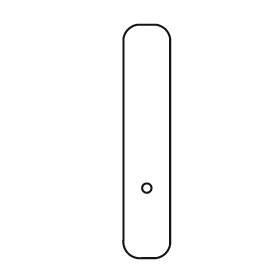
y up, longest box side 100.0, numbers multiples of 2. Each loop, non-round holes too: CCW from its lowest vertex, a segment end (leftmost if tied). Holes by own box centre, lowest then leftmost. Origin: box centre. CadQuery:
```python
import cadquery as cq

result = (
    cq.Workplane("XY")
    .moveTo(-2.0, -50.0)
    .lineTo(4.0, -50.0)
    .threePointArc((8.0, -48.0), (10.0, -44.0))
    .lineTo(10.0, 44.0)
    .threePointArc((8.0, 48.0), (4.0, 50.0))
    .lineTo(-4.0, 50.0)
    .threePointArc((-8.0, 48.0), (-10.0, 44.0))
    .lineTo(-10.0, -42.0)
    .threePointArc((-8.0, -48.0), (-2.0, -50.0))
    .close()
    .moveTo(0.0, -20.0)
    .circle(2.0)
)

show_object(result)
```